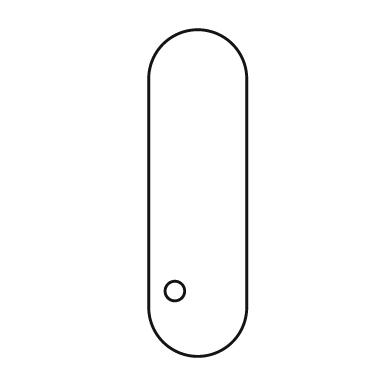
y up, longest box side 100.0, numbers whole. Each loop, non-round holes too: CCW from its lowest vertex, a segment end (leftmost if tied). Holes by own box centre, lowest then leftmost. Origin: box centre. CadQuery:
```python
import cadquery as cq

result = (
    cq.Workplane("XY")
    .moveTo(-15.0, -35.0)
    .threePointArc((0.0, -50.0), (15.0, -35.0))
    .lineTo(15.0, 35.0)
    .threePointArc((0.0, 50.0), (-15.0, 35.0))
    .close()
    .moveTo(-7.0, -30.0)
    .circle(3.0)
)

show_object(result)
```